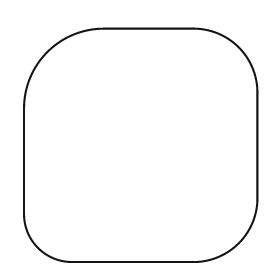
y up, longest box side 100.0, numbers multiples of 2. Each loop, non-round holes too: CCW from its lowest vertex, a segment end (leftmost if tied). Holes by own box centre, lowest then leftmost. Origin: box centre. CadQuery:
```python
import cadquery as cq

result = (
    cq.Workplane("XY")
    .moveTo(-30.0, -50.0)
    .lineTo(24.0, -50.0)
    .threePointArc((42.0, -42.0), (50.0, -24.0))
    .lineTo(50.0, 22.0)
    .threePointArc((42.0, 42.0), (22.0, 50.0))
    .lineTo(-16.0, 50.0)
    .threePointArc((-40.0, 40.0), (-50.0, 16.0))
    .lineTo(-50.0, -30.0)
    .threePointArc((-44.0, -44.0), (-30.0, -50.0))
    .close()
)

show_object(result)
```